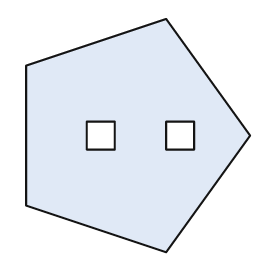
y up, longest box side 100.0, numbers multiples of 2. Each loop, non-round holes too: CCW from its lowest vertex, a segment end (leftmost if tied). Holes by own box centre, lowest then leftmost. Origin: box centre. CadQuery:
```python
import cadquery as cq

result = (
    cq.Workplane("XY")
    .moveTo(12.0, -50.0)
    .lineTo(48.0, 0.0)
    .lineTo(12.0, 50.0)
    .lineTo(-48.0, 30.0)
    .lineTo(-48.0, -30.0)
    .close()
    .moveTo(-22.0, -6.0)
    .lineTo(-10.0, -6.0)
    .lineTo(-10.0, 6.0)
    .lineTo(-22.0, 6.0)
    .close()
    .moveTo(12.0, -6.0)
    .lineTo(24.0, -6.0)
    .lineTo(24.0, 6.0)
    .lineTo(12.0, 6.0)
    .close()
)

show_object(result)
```